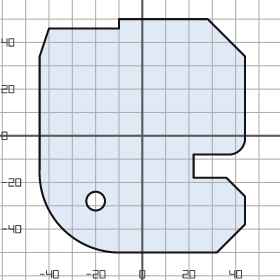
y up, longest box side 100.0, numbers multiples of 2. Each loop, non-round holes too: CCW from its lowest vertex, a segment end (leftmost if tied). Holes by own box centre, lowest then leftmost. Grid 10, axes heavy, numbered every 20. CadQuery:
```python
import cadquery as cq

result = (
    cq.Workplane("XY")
    .moveTo(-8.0, -50.0)
    .lineTo(32.0, -50.0)
    .lineTo(44.0, -38.0)
    .lineTo(44.0, -26.0)
    .lineTo(36.0, -18.0)
    .lineTo(22.0, -18.0)
    .lineTo(22.0, -8.0)
    .lineTo(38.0, -8.0)
    .threePointArc((42.0, -6.0), (44.0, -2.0))
    .lineTo(44.0, 34.0)
    .lineTo(28.0, 50.0)
    .lineTo(-10.0, 50.0)
    .lineTo(-10.0, 46.0)
    .lineTo(-40.0, 46.0)
    .lineTo(-44.0, 34.0)
    .lineTo(-44.0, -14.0)
    .threePointArc((-34.0, -40.0), (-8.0, -50.0))
    .close()
    .moveTo(-20.0, -28.0)
    .circle(4.0)
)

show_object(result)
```